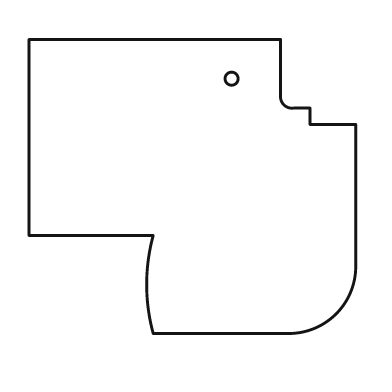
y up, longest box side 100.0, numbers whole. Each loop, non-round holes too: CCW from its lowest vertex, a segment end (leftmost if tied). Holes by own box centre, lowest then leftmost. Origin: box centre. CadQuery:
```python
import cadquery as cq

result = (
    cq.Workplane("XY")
    .moveTo(-12.0, -45.0)
    .lineTo(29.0, -45.0)
    .threePointArc((44.0, -39.0), (50.0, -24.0))
    .lineTo(50.0, 19.0)
    .lineTo(36.0, 19.0)
    .lineTo(36.0, 24.0)
    .lineTo(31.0, 24.0)
    .threePointArc((28.0, 25.0), (27.0, 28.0))
    .lineTo(27.0, 45.0)
    .lineTo(-50.0, 45.0)
    .lineTo(-50.0, -15.0)
    .lineTo(-12.0, -15.0)
    .threePointArc((-14.0, -30.0), (-12.0, -45.0))
    .close()
    .moveTo(12.0, 33.0)
    .circle(2.0)
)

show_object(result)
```